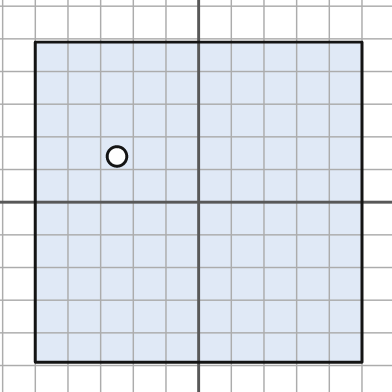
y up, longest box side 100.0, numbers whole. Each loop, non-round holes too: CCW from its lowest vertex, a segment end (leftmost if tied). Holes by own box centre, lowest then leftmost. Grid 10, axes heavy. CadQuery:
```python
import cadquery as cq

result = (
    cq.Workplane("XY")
    .moveTo(-50.0, -49.0)
    .lineTo(50.0, -49.0)
    .lineTo(50.0, 49.0)
    .lineTo(-50.0, 49.0)
    .close()
    .moveTo(-25.0, 14.0)
    .circle(3.0)
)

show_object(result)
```